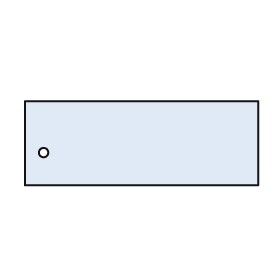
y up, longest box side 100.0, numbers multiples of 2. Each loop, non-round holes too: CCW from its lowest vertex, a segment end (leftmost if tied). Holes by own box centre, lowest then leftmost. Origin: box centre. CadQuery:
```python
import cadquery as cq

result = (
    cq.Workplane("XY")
    .moveTo(-50.0, -18.0)
    .lineTo(50.0, -18.0)
    .lineTo(50.0, 18.0)
    .lineTo(-50.0, 18.0)
    .close()
    .moveTo(-42.0, -4.0)
    .circle(2.0)
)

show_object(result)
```